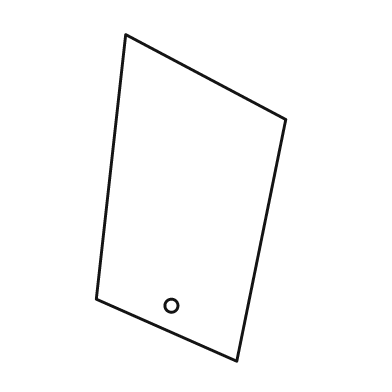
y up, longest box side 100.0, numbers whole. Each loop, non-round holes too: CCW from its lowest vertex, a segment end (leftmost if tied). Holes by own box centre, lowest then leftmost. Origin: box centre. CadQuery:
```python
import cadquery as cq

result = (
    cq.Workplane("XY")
    .moveTo(14.0, -50.0)
    .lineTo(29.0, 24.0)
    .lineTo(-20.0, 50.0)
    .lineTo(-29.0, -31.0)
    .close()
    .moveTo(-6.0, -33.0)
    .circle(2.0)
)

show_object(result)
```